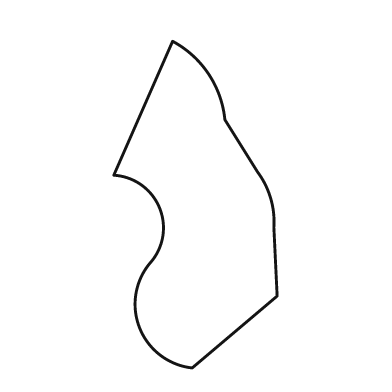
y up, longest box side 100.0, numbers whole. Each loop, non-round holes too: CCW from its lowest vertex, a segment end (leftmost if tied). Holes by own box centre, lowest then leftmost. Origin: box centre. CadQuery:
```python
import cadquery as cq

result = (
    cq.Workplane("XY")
    .moveTo(-1.0, -50.0)
    .lineTo(25.0, -28.0)
    .lineTo(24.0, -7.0)
    .threePointArc((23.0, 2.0), (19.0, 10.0))
    .lineTo(9.0, 26.0)
    .threePointArc((4.0, 40.0), (-7.0, 50.0))
    .lineTo(-25.0, 9.0)
    .threePointArc((-11.0, -1.0), (-14.0, -18.0))
    .threePointArc((-17.0, -38.0), (-1.0, -50.0))
    .close()
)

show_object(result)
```